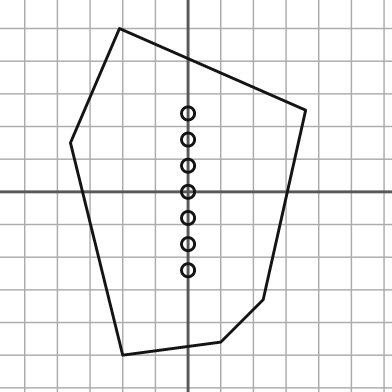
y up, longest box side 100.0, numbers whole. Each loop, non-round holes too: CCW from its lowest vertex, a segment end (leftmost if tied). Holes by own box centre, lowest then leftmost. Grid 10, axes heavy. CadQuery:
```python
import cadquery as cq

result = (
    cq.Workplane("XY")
    .moveTo(-20.0, -50.0)
    .lineTo(10.0, -46.0)
    .lineTo(23.0, -33.0)
    .lineTo(36.0, 25.0)
    .lineTo(-21.0, 50.0)
    .lineTo(-36.0, 15.0)
    .close()
    .moveTo(0.0, -24.0)
    .circle(2.0)
    .moveTo(0.0, -16.0)
    .circle(2.0)
    .moveTo(0.0, -8.0)
    .circle(2.0)
    .moveTo(0.0, 0.0)
    .circle(2.0)
    .moveTo(0.0, 8.0)
    .circle(2.0)
    .moveTo(0.0, 16.0)
    .circle(2.0)
    .moveTo(0.0, 24.0)
    .circle(2.0)
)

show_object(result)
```